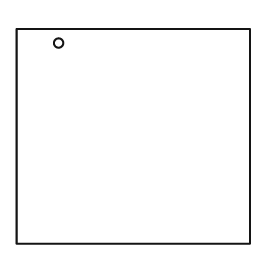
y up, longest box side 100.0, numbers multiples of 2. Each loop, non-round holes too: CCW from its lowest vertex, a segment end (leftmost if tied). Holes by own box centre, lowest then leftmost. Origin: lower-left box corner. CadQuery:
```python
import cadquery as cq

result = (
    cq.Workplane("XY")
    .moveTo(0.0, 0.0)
    .lineTo(100.0, 0.0)
    .lineTo(100.0, 92.0)
    .lineTo(0.0, 92.0)
    .close()
    .moveTo(18.0, 86.0)
    .circle(2.0)
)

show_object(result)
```